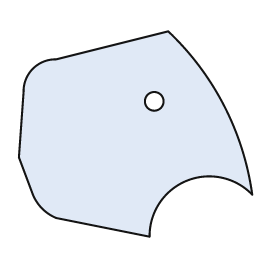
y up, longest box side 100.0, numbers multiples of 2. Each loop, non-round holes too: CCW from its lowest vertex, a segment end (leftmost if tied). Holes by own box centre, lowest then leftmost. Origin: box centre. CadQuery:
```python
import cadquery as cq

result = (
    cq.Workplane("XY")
    .moveTo(6.0, -44.0)
    .threePointArc((22.0, -20.0), (50.0, -26.0))
    .threePointArc((38.0, 12.0), (14.0, 44.0))
    .lineTo(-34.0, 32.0)
    .threePointArc((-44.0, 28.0), (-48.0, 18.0))
    .lineTo(-50.0, -10.0)
    .lineTo(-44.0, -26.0)
    .threePointArc((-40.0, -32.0), (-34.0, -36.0))
    .close()
    .moveTo(8.0, 14.0)
    .circle(4.0)
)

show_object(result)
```